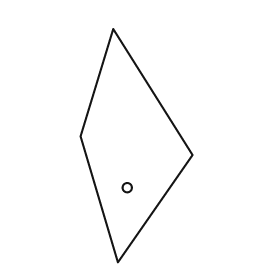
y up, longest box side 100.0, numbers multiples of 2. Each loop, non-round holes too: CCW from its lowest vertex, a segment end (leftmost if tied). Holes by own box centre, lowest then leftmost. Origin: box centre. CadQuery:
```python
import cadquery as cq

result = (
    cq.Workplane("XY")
    .moveTo(-8.0, -50.0)
    .lineTo(24.0, -4.0)
    .lineTo(-10.0, 50.0)
    .lineTo(-24.0, 4.0)
    .close()
    .moveTo(-4.0, -18.0)
    .circle(2.0)
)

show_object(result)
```